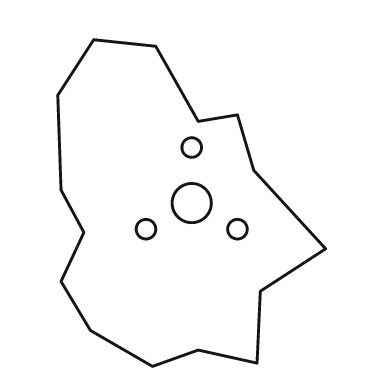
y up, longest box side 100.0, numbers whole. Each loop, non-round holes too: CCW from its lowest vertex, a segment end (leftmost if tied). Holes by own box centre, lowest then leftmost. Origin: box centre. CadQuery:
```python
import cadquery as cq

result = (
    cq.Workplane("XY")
    .moveTo(-12.0, -50.0)
    .lineTo(2.0, -45.0)
    .lineTo(20.0, -49.0)
    .lineTo(21.0, -27.0)
    .lineTo(41.0, -14.0)
    .lineTo(19.0, 10.0)
    .lineTo(14.0, 27.0)
    .lineTo(2.0, 25.0)
    .lineTo(-11.0, 48.0)
    .lineTo(-30.0, 50.0)
    .lineTo(-41.0, 33.0)
    .lineTo(-40.0, 4.0)
    .lineTo(-33.0, -9.0)
    .lineTo(-40.0, -24.0)
    .lineTo(-31.0, -39.0)
    .close()
    .moveTo(-14.0, -8.0)
    .circle(3.0)
    .moveTo(14.0, -8.0)
    .circle(3.0)
    .moveTo(0.0, 0.0)
    .circle(6.0)
    .moveTo(0.0, 17.0)
    .circle(3.0)
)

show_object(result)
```